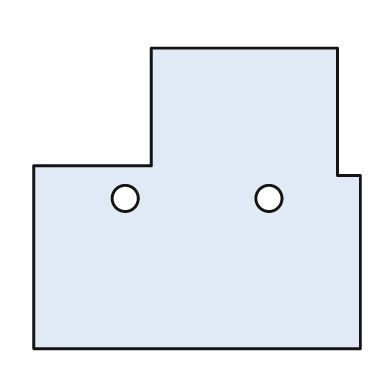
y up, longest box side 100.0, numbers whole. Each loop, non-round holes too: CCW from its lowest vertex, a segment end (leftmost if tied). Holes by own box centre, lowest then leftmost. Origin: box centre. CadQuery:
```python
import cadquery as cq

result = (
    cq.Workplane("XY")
    .moveTo(-50.0, -46.0)
    .lineTo(50.0, -46.0)
    .lineTo(50.0, 7.0)
    .lineTo(43.0, 7.0)
    .lineTo(43.0, 46.0)
    .lineTo(-14.0, 46.0)
    .lineTo(-14.0, 10.0)
    .lineTo(-50.0, 10.0)
    .close()
    .moveTo(-22.0, 0.0)
    .circle(4.0)
    .moveTo(22.0, 0.0)
    .circle(4.0)
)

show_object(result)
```